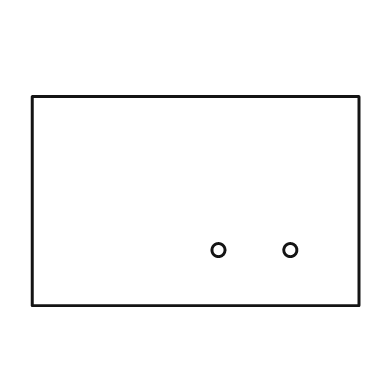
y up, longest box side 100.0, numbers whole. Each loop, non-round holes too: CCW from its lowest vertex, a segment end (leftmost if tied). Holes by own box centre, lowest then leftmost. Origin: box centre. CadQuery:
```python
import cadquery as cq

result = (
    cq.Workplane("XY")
    .moveTo(-50.0, -32.0)
    .lineTo(50.0, -32.0)
    .lineTo(50.0, 32.0)
    .lineTo(-50.0, 32.0)
    .close()
    .moveTo(7.0, -15.0)
    .circle(2.0)
    .moveTo(29.0, -15.0)
    .circle(2.0)
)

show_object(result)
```